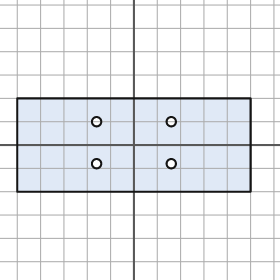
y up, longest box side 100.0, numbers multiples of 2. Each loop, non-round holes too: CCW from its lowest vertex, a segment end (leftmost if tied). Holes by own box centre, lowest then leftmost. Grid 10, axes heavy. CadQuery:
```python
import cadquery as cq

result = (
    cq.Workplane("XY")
    .moveTo(-50.0, -20.0)
    .lineTo(50.0, -20.0)
    .lineTo(50.0, 20.0)
    .lineTo(-50.0, 20.0)
    .close()
    .moveTo(-16.0, -8.0)
    .circle(2.0)
    .moveTo(16.0, -8.0)
    .circle(2.0)
    .moveTo(-16.0, 10.0)
    .circle(2.0)
    .moveTo(16.0, 10.0)
    .circle(2.0)
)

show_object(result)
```